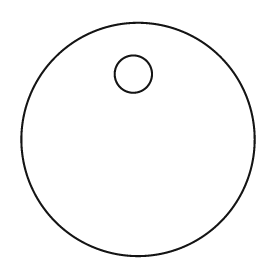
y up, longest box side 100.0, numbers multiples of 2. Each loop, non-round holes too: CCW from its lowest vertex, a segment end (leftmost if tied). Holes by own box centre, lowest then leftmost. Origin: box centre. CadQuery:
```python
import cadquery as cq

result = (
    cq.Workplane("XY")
    .moveTo(0.0, 0.0)
    .circle(50.0)
    .moveTo(-2.0, 28.0)
    .circle(8.0)
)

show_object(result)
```